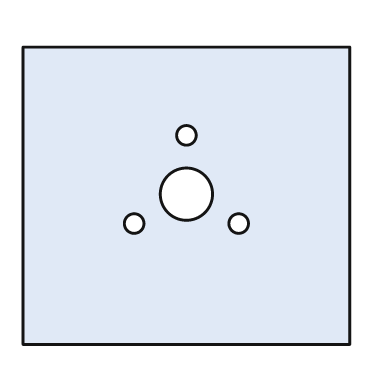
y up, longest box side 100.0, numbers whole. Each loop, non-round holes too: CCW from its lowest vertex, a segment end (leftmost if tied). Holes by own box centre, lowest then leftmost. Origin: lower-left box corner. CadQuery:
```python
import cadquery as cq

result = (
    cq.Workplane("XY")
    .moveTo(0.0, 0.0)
    .lineTo(100.0, 0.0)
    .lineTo(100.0, 91.0)
    .lineTo(0.0, 91.0)
    .close()
    .moveTo(34.0, 37.0)
    .circle(3.0)
    .moveTo(66.0, 37.0)
    .circle(3.0)
    .moveTo(50.0, 46.0)
    .circle(8.0)
    .moveTo(50.0, 64.0)
    .circle(3.0)
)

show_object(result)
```